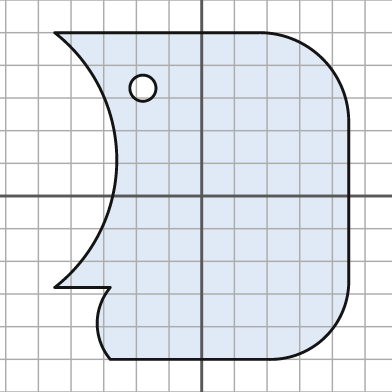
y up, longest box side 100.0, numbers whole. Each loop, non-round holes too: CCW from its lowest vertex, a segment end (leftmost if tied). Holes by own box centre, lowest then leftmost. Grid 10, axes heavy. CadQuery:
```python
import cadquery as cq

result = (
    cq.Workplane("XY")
    .moveTo(-28.0, -50.0)
    .lineTo(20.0, -50.0)
    .threePointArc((38.0, -43.0), (45.0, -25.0))
    .lineTo(45.0, 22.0)
    .threePointArc((37.0, 42.0), (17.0, 50.0))
    .lineTo(-45.0, 50.0)
    .threePointArc((-26.0, 11.0), (-45.0, -28.0))
    .lineTo(-28.0, -28.0)
    .threePointArc((-32.0, -39.0), (-28.0, -50.0))
    .close()
    .moveTo(-18.0, 33.0)
    .circle(4.0)
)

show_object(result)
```